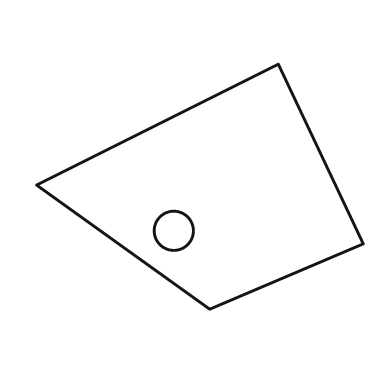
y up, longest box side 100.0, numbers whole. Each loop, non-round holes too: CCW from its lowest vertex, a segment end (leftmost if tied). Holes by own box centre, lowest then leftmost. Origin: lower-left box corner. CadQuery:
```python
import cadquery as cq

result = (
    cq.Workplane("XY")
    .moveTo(53.0, 0.0)
    .lineTo(100.0, 20.0)
    .lineTo(74.0, 75.0)
    .lineTo(0.0, 38.0)
    .close()
    .moveTo(42.0, 24.0)
    .circle(6.0)
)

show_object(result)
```